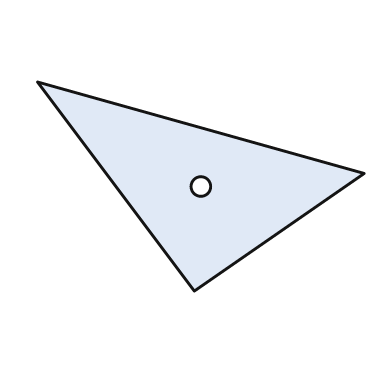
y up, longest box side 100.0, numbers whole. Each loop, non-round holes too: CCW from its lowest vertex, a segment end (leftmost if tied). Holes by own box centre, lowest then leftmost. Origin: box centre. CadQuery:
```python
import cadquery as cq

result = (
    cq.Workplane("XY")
    .moveTo(-2.0, -32.0)
    .lineTo(50.0, 4.0)
    .lineTo(-50.0, 32.0)
    .close()
    .moveTo(0.0, 0.0)
    .circle(3.0)
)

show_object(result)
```